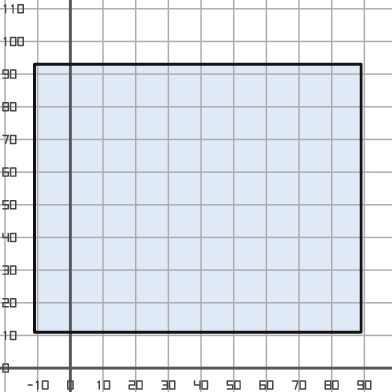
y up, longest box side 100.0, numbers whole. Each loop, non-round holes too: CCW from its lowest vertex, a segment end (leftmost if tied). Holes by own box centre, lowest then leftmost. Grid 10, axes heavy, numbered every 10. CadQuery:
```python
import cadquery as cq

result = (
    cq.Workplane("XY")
    .moveTo(-11.0, 11.0)
    .lineTo(89.0, 11.0)
    .lineTo(89.0, 93.0)
    .lineTo(-11.0, 93.0)
    .close()
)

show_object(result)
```